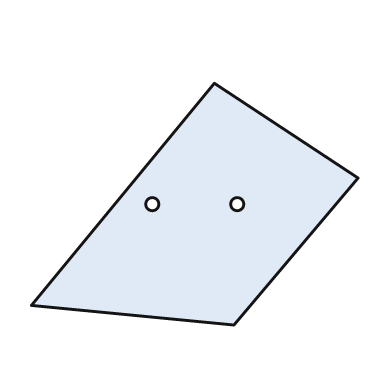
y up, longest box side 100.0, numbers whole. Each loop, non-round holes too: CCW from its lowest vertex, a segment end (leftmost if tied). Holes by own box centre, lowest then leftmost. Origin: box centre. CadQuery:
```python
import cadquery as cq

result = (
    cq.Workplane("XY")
    .moveTo(12.0, -37.0)
    .lineTo(50.0, 8.0)
    .lineTo(6.0, 37.0)
    .lineTo(-50.0, -31.0)
    .close()
    .moveTo(-13.0, 0.0)
    .circle(2.0)
    .moveTo(13.0, 0.0)
    .circle(2.0)
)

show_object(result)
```